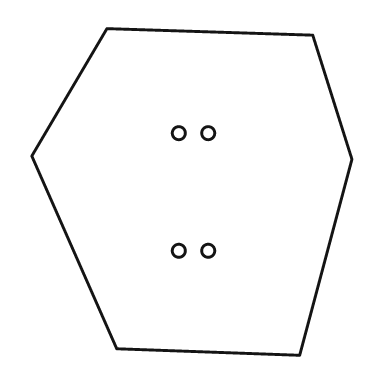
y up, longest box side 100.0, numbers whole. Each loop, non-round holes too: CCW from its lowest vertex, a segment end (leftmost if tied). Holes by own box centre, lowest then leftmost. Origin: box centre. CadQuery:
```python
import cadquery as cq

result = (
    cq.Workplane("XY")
    .moveTo(33.0, -50.0)
    .lineTo(49.0, 10.0)
    .lineTo(37.0, 48.0)
    .lineTo(-26.0, 50.0)
    .lineTo(-49.0, 11.0)
    .lineTo(-23.0, -48.0)
    .close()
    .moveTo(-4.0, -18.0)
    .circle(2.0)
    .moveTo(5.0, -18.0)
    .circle(2.0)
    .moveTo(-4.0, 18.0)
    .circle(2.0)
    .moveTo(5.0, 18.0)
    .circle(2.0)
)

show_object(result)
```